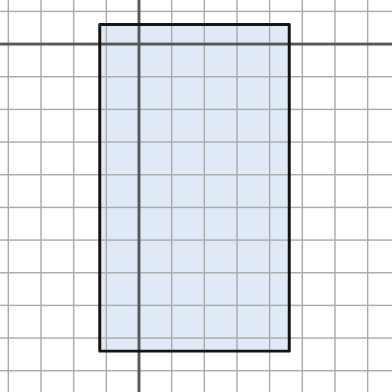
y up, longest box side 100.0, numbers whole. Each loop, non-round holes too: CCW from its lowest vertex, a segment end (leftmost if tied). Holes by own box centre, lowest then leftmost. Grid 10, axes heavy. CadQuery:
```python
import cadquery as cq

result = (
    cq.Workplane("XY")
    .moveTo(-12.0, -94.0)
    .lineTo(46.0, -94.0)
    .lineTo(46.0, 6.0)
    .lineTo(-12.0, 6.0)
    .close()
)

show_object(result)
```